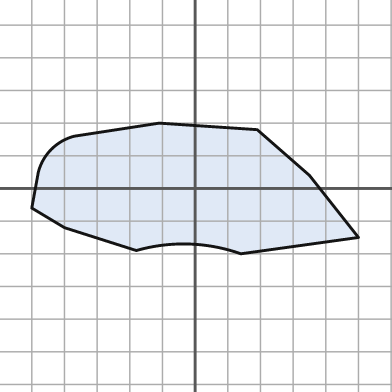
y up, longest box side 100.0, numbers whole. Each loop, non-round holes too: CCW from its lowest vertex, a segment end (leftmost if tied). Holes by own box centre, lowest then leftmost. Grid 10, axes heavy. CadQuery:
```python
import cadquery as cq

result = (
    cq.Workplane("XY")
    .moveTo(14.0, -20.0)
    .lineTo(50.0, -15.0)
    .lineTo(35.0, 4.0)
    .lineTo(19.0, 18.0)
    .lineTo(-11.0, 20.0)
    .lineTo(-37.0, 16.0)
    .threePointArc((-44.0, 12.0), (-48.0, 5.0))
    .lineTo(-50.0, -6.0)
    .lineTo(-40.0, -12.0)
    .lineTo(-18.0, -19.0)
    .threePointArc((-2.0, -17.0), (14.0, -20.0))
    .close()
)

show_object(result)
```